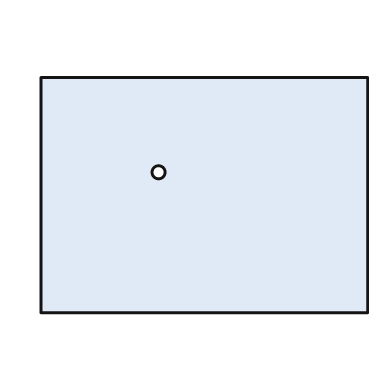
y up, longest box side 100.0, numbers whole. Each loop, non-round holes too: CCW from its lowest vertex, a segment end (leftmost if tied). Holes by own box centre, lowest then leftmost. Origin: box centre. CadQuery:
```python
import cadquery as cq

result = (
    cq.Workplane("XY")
    .moveTo(-50.0, -36.0)
    .lineTo(50.0, -36.0)
    .lineTo(50.0, 36.0)
    .lineTo(-50.0, 36.0)
    .close()
    .moveTo(-14.0, 7.0)
    .circle(2.0)
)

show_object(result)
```